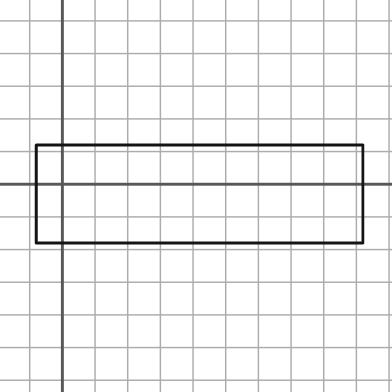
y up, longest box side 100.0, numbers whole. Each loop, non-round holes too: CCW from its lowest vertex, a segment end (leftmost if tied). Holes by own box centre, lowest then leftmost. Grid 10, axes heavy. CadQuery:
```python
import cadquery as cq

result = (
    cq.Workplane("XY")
    .moveTo(-8.0, -18.0)
    .lineTo(92.0, -18.0)
    .lineTo(92.0, 12.0)
    .lineTo(-8.0, 12.0)
    .close()
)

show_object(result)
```